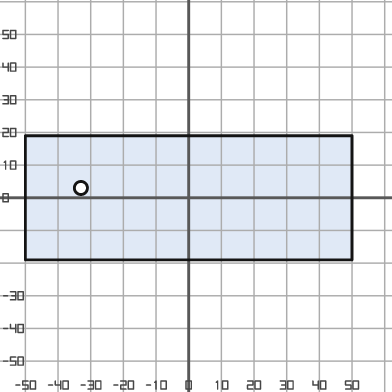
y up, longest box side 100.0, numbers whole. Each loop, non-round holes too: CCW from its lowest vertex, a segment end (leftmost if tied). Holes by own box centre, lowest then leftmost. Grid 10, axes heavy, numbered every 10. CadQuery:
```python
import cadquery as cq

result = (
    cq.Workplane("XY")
    .moveTo(-50.0, -19.0)
    .lineTo(50.0, -19.0)
    .lineTo(50.0, 19.0)
    .lineTo(-50.0, 19.0)
    .close()
    .moveTo(-33.0, 3.0)
    .circle(2.0)
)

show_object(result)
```